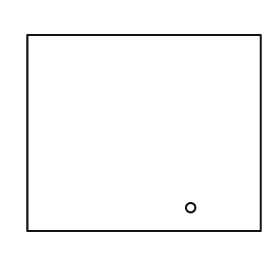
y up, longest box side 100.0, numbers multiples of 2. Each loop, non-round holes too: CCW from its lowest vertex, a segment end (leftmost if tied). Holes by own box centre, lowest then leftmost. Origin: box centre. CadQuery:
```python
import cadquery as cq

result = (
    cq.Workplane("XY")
    .moveTo(-50.0, -42.0)
    .lineTo(50.0, -42.0)
    .lineTo(50.0, 42.0)
    .lineTo(-50.0, 42.0)
    .close()
    .moveTo(20.0, -32.0)
    .circle(2.0)
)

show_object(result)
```